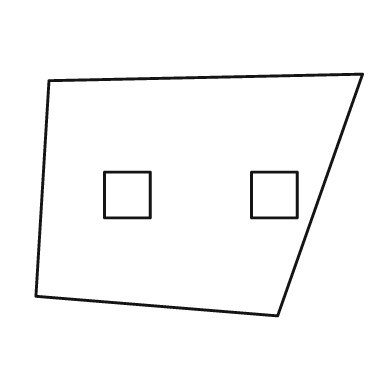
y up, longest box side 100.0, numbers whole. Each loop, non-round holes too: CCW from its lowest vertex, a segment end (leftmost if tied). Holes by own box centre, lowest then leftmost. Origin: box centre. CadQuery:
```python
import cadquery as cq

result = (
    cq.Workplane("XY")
    .moveTo(24.0, -37.0)
    .lineTo(50.0, 37.0)
    .lineTo(-46.0, 35.0)
    .lineTo(-50.0, -31.0)
    .close()
    .moveTo(-29.0, -7.0)
    .lineTo(-15.0, -7.0)
    .lineTo(-15.0, 7.0)
    .lineTo(-29.0, 7.0)
    .close()
    .moveTo(16.0, -7.0)
    .lineTo(30.0, -7.0)
    .lineTo(30.0, 7.0)
    .lineTo(16.0, 7.0)
    .close()
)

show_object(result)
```